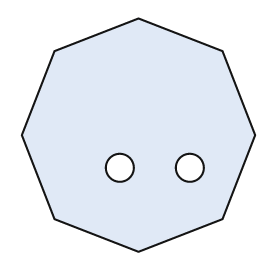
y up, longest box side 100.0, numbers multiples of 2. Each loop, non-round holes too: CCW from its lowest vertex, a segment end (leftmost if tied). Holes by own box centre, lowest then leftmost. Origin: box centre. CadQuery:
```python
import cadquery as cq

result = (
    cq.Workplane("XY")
    .moveTo(0.0, -50.0)
    .lineTo(36.0, -36.0)
    .lineTo(50.0, 0.0)
    .lineTo(36.0, 36.0)
    .lineTo(0.0, 50.0)
    .lineTo(-36.0, 36.0)
    .lineTo(-50.0, 0.0)
    .lineTo(-36.0, -36.0)
    .close()
    .moveTo(-8.0, -14.0)
    .circle(6.0)
    .moveTo(22.0, -14.0)
    .circle(6.0)
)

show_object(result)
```